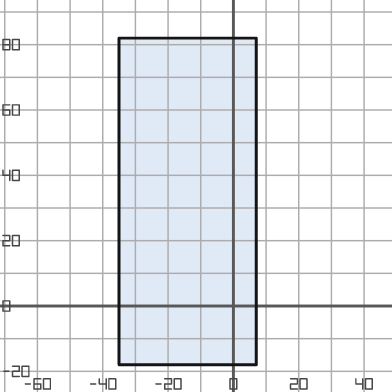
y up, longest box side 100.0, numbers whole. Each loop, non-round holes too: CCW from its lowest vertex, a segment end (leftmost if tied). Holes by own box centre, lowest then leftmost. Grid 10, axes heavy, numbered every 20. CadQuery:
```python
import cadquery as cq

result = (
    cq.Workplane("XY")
    .moveTo(-35.0, -18.0)
    .lineTo(7.0, -18.0)
    .lineTo(7.0, 82.0)
    .lineTo(-35.0, 82.0)
    .close()
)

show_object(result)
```